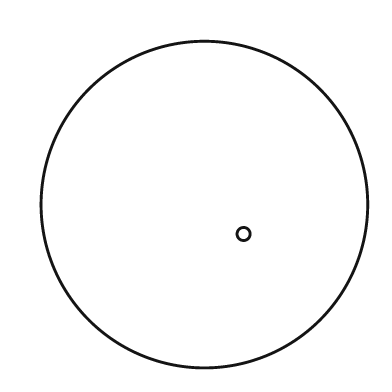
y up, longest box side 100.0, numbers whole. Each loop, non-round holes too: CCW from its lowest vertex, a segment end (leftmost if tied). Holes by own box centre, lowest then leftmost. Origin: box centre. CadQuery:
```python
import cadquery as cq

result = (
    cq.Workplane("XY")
    .moveTo(0.0, 0.0)
    .circle(50.0)
    .moveTo(12.0, -9.0)
    .circle(2.0)
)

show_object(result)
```